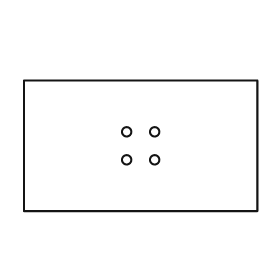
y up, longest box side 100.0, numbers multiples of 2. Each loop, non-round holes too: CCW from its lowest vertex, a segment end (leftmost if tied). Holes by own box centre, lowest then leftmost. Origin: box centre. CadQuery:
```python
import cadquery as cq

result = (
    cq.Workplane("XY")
    .moveTo(-50.0, -28.0)
    .lineTo(50.0, -28.0)
    .lineTo(50.0, 28.0)
    .lineTo(-50.0, 28.0)
    .close()
    .moveTo(-6.0, -6.0)
    .circle(2.0)
    .moveTo(6.0, -6.0)
    .circle(2.0)
    .moveTo(-6.0, 6.0)
    .circle(2.0)
    .moveTo(6.0, 6.0)
    .circle(2.0)
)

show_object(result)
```